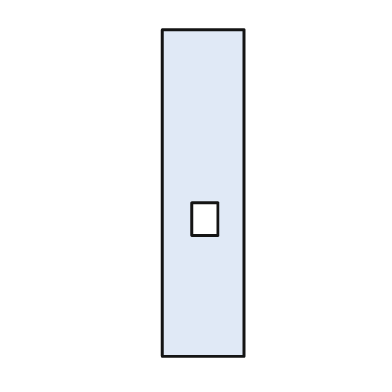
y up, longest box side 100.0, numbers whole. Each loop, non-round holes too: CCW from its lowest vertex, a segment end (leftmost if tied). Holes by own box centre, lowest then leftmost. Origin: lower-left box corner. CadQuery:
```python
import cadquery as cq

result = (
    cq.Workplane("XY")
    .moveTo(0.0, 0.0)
    .lineTo(25.0, 0.0)
    .lineTo(25.0, 100.0)
    .lineTo(0.0, 100.0)
    .close()
    .moveTo(9.0, 37.0)
    .lineTo(17.0, 37.0)
    .lineTo(17.0, 47.0)
    .lineTo(9.0, 47.0)
    .close()
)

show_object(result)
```